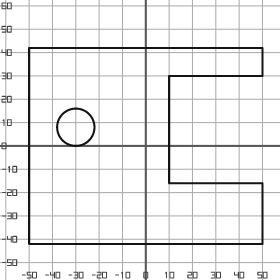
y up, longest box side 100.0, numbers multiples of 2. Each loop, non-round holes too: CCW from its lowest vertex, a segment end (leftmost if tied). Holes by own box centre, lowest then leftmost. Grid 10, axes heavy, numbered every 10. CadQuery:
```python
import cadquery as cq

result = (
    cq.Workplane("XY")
    .moveTo(-50.0, -42.0)
    .lineTo(50.0, -42.0)
    .lineTo(50.0, -16.0)
    .lineTo(10.0, -16.0)
    .lineTo(10.0, 30.0)
    .lineTo(50.0, 30.0)
    .lineTo(50.0, 42.0)
    .lineTo(-50.0, 42.0)
    .close()
    .moveTo(-30.0, 8.0)
    .circle(8.0)
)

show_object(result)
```